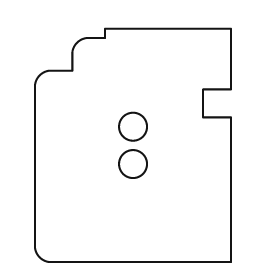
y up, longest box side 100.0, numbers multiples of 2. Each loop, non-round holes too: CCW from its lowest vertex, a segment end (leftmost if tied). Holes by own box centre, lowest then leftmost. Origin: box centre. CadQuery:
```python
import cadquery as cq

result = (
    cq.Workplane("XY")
    .moveTo(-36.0, -50.0)
    .lineTo(42.0, -50.0)
    .lineTo(42.0, 12.0)
    .lineTo(30.0, 12.0)
    .lineTo(30.0, 24.0)
    .lineTo(42.0, 24.0)
    .lineTo(42.0, 50.0)
    .lineTo(-12.0, 50.0)
    .lineTo(-12.0, 46.0)
    .lineTo(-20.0, 46.0)
    .threePointArc((-24.0, 44.0), (-26.0, 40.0))
    .lineTo(-26.0, 32.0)
    .lineTo(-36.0, 32.0)
    .threePointArc((-40.0, 30.0), (-42.0, 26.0))
    .lineTo(-42.0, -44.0)
    .threePointArc((-40.0, -48.0), (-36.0, -50.0))
    .close()
    .moveTo(0.0, -8.0)
    .circle(6.0)
    .moveTo(0.0, 8.0)
    .circle(6.0)
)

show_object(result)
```